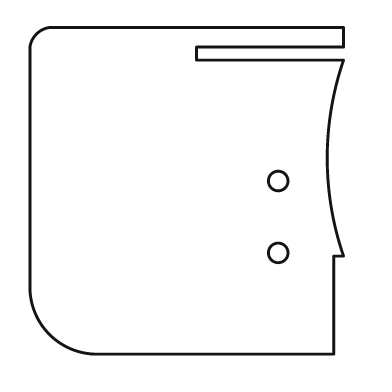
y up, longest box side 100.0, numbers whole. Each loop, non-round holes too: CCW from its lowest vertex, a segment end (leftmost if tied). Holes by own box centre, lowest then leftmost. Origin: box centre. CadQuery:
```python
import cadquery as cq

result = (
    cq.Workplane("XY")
    .moveTo(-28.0, -50.0)
    .lineTo(45.0, -50.0)
    .lineTo(45.0, -20.0)
    .lineTo(48.0, -20.0)
    .threePointArc((43.0, 10.0), (48.0, 40.0))
    .lineTo(3.0, 40.0)
    .lineTo(3.0, 44.0)
    .lineTo(48.0, 44.0)
    .lineTo(48.0, 50.0)
    .lineTo(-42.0, 50.0)
    .threePointArc((-46.0, 48.0), (-48.0, 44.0))
    .lineTo(-48.0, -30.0)
    .threePointArc((-42.0, -44.0), (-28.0, -50.0))
    .close()
    .moveTo(28.0, -19.0)
    .circle(3.0)
    .moveTo(28.0, 3.0)
    .circle(3.0)
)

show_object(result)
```